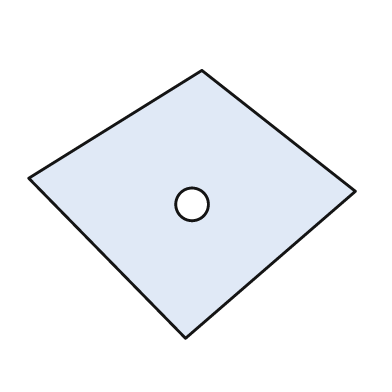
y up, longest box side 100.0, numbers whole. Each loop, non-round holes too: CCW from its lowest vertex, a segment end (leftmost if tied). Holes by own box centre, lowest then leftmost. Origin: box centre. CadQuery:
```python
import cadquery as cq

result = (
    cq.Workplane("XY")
    .moveTo(-2.0, -41.0)
    .lineTo(50.0, 4.0)
    .lineTo(3.0, 41.0)
    .lineTo(-50.0, 8.0)
    .close()
    .moveTo(0.0, 0.0)
    .circle(5.0)
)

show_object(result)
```